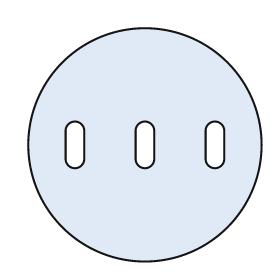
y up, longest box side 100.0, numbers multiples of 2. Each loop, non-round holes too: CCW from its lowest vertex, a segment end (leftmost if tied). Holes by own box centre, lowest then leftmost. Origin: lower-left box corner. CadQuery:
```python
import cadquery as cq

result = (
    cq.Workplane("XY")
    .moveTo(50.0, 50.0)
    .circle(50.0)
    .moveTo(16.0, 44.0)
    .threePointArc((20.0, 40.0), (24.0, 44.0))
    .lineTo(24.0, 56.0)
    .threePointArc((20.0, 60.0), (16.0, 56.0))
    .close()
    .moveTo(46.0, 44.0)
    .threePointArc((50.0, 40.0), (54.0, 44.0))
    .lineTo(54.0, 56.0)
    .threePointArc((50.0, 60.0), (46.0, 56.0))
    .close()
    .moveTo(76.0, 44.0)
    .threePointArc((80.0, 40.0), (84.0, 44.0))
    .lineTo(84.0, 56.0)
    .threePointArc((80.0, 60.0), (76.0, 56.0))
    .close()
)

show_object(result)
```